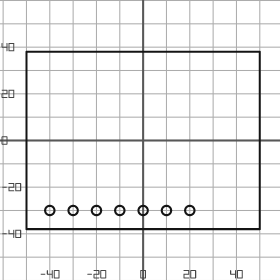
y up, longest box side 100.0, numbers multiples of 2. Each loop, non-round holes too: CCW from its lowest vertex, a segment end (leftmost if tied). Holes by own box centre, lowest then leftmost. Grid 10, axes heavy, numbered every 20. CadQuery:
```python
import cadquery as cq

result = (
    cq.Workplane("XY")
    .moveTo(-50.0, -38.0)
    .lineTo(50.0, -38.0)
    .lineTo(50.0, 38.0)
    .lineTo(-50.0, 38.0)
    .close()
    .moveTo(-40.0, -30.0)
    .circle(2.0)
    .moveTo(-30.0, -30.0)
    .circle(2.0)
    .moveTo(-20.0, -30.0)
    .circle(2.0)
    .moveTo(-10.0, -30.0)
    .circle(2.0)
    .moveTo(0.0, -30.0)
    .circle(2.0)
    .moveTo(10.0, -30.0)
    .circle(2.0)
    .moveTo(20.0, -30.0)
    .circle(2.0)
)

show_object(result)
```